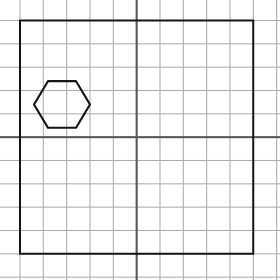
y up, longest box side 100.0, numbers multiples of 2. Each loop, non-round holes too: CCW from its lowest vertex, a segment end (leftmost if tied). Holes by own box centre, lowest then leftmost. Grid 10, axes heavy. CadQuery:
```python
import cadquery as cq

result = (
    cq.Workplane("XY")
    .moveTo(-50.0, -50.0)
    .lineTo(50.0, -50.0)
    .lineTo(50.0, 50.0)
    .lineTo(-50.0, 50.0)
    .close()
    .moveTo(-38.0, 4.0)
    .lineTo(-26.0, 4.0)
    .lineTo(-20.0, 14.0)
    .lineTo(-26.0, 24.0)
    .lineTo(-38.0, 24.0)
    .lineTo(-44.0, 14.0)
    .close()
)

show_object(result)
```